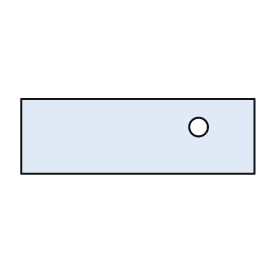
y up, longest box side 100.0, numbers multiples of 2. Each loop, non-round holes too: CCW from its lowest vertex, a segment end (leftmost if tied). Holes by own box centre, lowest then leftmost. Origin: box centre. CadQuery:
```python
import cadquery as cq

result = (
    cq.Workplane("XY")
    .moveTo(-50.0, -16.0)
    .lineTo(50.0, -16.0)
    .lineTo(50.0, 16.0)
    .lineTo(-50.0, 16.0)
    .close()
    .moveTo(26.0, 4.0)
    .circle(4.0)
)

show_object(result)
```